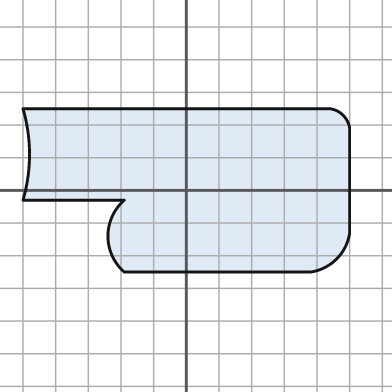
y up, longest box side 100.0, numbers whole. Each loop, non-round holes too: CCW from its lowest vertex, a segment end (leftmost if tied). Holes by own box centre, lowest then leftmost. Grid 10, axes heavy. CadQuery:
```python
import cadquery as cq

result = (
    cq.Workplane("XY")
    .moveTo(-19.0, -25.0)
    .lineTo(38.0, -25.0)
    .threePointArc((46.0, -21.0), (50.0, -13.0))
    .lineTo(50.0, 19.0)
    .threePointArc((48.0, 23.0), (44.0, 25.0))
    .lineTo(-50.0, 25.0)
    .threePointArc((-48.0, 11.0), (-50.0, -3.0))
    .lineTo(-19.0, -3.0)
    .threePointArc((-24.0, -14.0), (-19.0, -25.0))
    .close()
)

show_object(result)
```